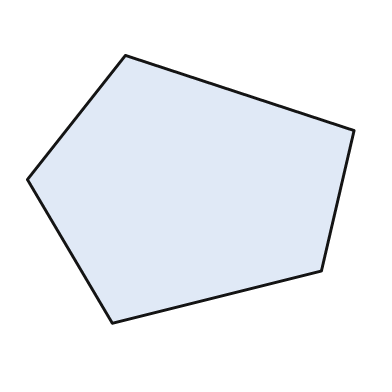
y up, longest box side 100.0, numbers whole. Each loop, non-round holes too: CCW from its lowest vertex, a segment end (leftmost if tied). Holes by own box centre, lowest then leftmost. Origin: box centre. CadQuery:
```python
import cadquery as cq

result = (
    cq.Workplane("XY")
    .moveTo(-24.0, -41.0)
    .lineTo(40.0, -25.0)
    .lineTo(50.0, 18.0)
    .lineTo(-20.0, 41.0)
    .lineTo(-50.0, 3.0)
    .close()
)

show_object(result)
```